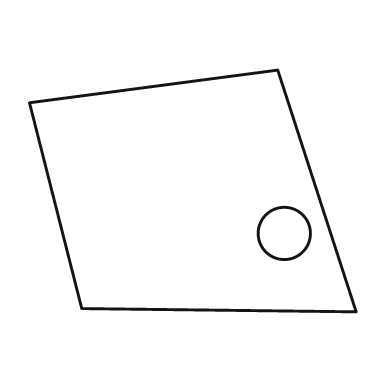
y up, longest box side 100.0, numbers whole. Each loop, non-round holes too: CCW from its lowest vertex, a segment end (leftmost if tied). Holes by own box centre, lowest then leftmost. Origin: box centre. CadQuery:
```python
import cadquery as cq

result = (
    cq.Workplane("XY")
    .moveTo(50.0, -37.0)
    .lineTo(26.0, 37.0)
    .lineTo(-50.0, 27.0)
    .lineTo(-34.0, -36.0)
    .close()
    .moveTo(28.0, -13.0)
    .circle(8.0)
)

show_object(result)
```